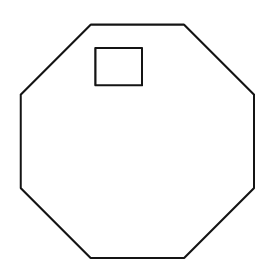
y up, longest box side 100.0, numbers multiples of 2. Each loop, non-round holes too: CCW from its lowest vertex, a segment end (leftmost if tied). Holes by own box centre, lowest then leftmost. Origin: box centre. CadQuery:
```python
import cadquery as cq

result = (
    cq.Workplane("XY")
    .moveTo(-20.0, -50.0)
    .lineTo(20.0, -50.0)
    .lineTo(50.0, -20.0)
    .lineTo(50.0, 20.0)
    .lineTo(20.0, 50.0)
    .lineTo(-20.0, 50.0)
    .lineTo(-50.0, 20.0)
    .lineTo(-50.0, -20.0)
    .close()
    .moveTo(-18.0, 24.0)
    .lineTo(2.0, 24.0)
    .lineTo(2.0, 40.0)
    .lineTo(-18.0, 40.0)
    .close()
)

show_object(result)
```